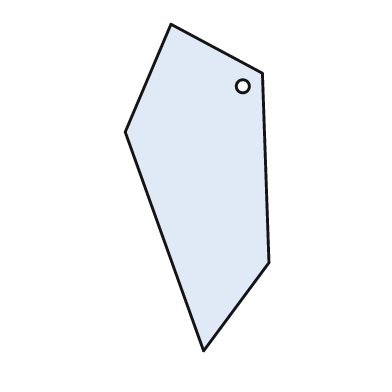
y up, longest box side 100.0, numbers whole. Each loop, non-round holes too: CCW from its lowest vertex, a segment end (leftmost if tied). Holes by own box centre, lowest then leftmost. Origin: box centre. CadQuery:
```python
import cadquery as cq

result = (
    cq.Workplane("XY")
    .moveTo(2.0, -50.0)
    .lineTo(22.0, -23.0)
    .lineTo(20.0, 35.0)
    .lineTo(-8.0, 50.0)
    .lineTo(-22.0, 17.0)
    .close()
    .moveTo(14.0, 31.0)
    .circle(2.0)
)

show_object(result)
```